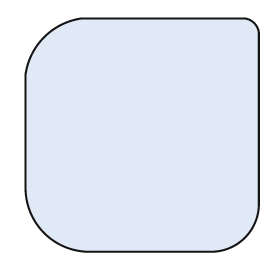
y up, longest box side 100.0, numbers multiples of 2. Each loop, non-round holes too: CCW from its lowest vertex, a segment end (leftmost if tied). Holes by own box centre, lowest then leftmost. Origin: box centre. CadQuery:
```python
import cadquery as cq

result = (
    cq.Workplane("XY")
    .moveTo(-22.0, -50.0)
    .lineTo(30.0, -50.0)
    .threePointArc((44.0, -44.0), (50.0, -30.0))
    .lineTo(50.0, 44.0)
    .threePointArc((48.0, 48.0), (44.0, 50.0))
    .lineTo(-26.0, 50.0)
    .threePointArc((-42.0, 42.0), (-50.0, 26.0))
    .lineTo(-50.0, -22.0)
    .threePointArc((-42.0, -42.0), (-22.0, -50.0))
    .close()
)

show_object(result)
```